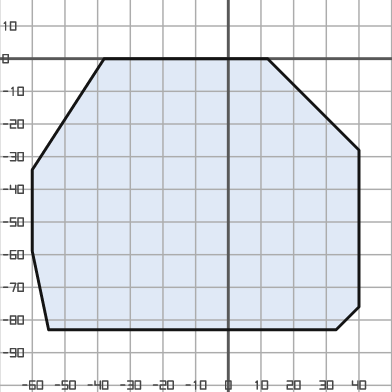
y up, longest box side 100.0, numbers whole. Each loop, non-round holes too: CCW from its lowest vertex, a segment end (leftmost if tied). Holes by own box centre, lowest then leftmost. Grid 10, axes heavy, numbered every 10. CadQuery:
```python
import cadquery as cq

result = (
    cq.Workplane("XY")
    .moveTo(-55.0, -83.0)
    .lineTo(33.0, -83.0)
    .lineTo(40.0, -76.0)
    .lineTo(40.0, -28.0)
    .lineTo(12.0, 0.0)
    .lineTo(-38.0, 0.0)
    .lineTo(-60.0, -34.0)
    .lineTo(-60.0, -59.0)
    .close()
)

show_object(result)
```